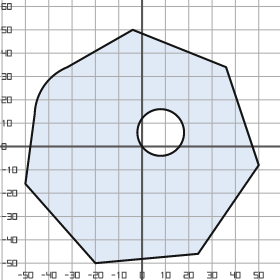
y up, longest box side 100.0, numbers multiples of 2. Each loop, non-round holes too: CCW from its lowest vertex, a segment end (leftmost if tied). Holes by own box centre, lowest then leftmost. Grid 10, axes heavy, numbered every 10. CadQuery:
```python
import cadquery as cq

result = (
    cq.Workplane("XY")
    .moveTo(-20.0, -50.0)
    .lineTo(24.0, -46.0)
    .lineTo(50.0, -8.0)
    .lineTo(36.0, 34.0)
    .lineTo(-4.0, 50.0)
    .lineTo(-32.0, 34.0)
    .threePointArc((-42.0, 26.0), (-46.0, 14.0))
    .lineTo(-50.0, -16.0)
    .close()
    .moveTo(8.0, 6.0)
    .circle(10.0)
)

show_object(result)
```